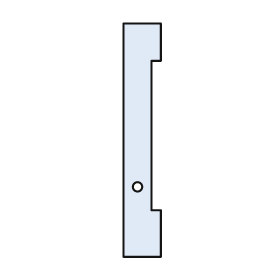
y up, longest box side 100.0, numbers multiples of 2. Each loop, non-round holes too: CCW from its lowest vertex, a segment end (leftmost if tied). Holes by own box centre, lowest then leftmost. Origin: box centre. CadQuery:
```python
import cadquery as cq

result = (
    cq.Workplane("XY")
    .moveTo(-8.0, -50.0)
    .lineTo(8.0, -50.0)
    .lineTo(8.0, -30.0)
    .lineTo(4.0, -30.0)
    .lineTo(4.0, 34.0)
    .lineTo(8.0, 34.0)
    .lineTo(8.0, 50.0)
    .lineTo(-8.0, 50.0)
    .close()
    .moveTo(-2.0, -20.0)
    .circle(2.0)
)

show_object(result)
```